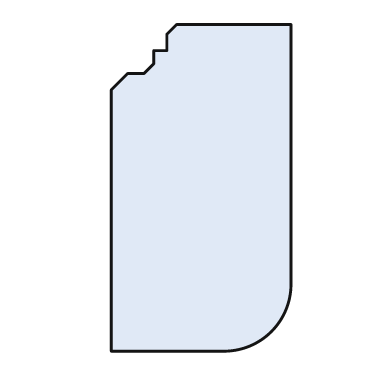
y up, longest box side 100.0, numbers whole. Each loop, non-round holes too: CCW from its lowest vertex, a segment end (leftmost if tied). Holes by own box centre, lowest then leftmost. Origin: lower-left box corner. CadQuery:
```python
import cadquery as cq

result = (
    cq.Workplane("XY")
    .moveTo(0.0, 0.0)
    .lineTo(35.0, 0.0)
    .threePointArc((49.0, 6.0), (55.0, 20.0))
    .lineTo(55.0, 100.0)
    .lineTo(20.0, 100.0)
    .lineTo(17.0, 97.0)
    .lineTo(17.0, 92.0)
    .lineTo(13.0, 92.0)
    .lineTo(13.0, 88.0)
    .lineTo(10.0, 85.0)
    .lineTo(5.0, 85.0)
    .lineTo(0.0, 80.0)
    .close()
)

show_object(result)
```